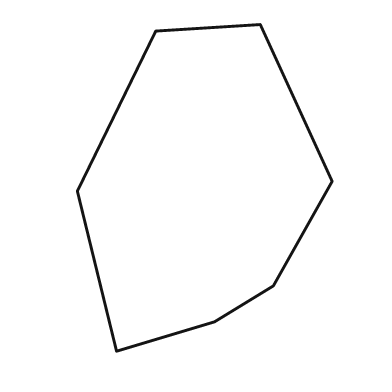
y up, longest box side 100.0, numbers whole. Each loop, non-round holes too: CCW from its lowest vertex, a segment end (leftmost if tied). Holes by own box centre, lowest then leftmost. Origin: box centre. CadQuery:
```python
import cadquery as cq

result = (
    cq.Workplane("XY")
    .moveTo(-27.0, -50.0)
    .lineTo(3.0, -41.0)
    .lineTo(21.0, -30.0)
    .lineTo(39.0, 2.0)
    .lineTo(17.0, 50.0)
    .lineTo(-15.0, 48.0)
    .lineTo(-39.0, -1.0)
    .close()
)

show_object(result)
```